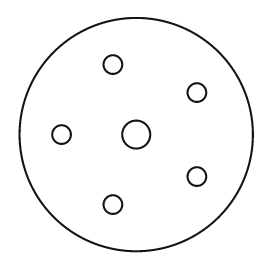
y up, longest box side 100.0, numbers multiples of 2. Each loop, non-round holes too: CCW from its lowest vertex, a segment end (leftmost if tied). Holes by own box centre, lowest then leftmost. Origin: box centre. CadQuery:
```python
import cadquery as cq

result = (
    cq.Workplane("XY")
    .moveTo(0.0, 0.0)
    .circle(50.0)
    .moveTo(-10.0, -30.0)
    .circle(4.0)
    .moveTo(26.0, -18.0)
    .circle(4.0)
    .moveTo(-32.0, 0.0)
    .circle(4.0)
    .moveTo(0.0, 0.0)
    .circle(6.0)
    .moveTo(26.0, 18.0)
    .circle(4.0)
    .moveTo(-10.0, 30.0)
    .circle(4.0)
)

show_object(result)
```